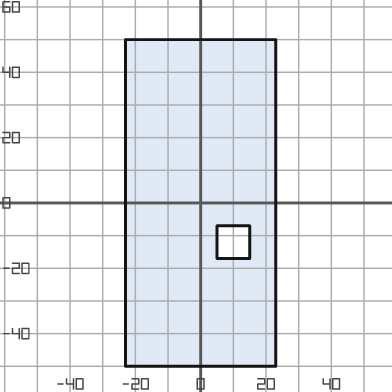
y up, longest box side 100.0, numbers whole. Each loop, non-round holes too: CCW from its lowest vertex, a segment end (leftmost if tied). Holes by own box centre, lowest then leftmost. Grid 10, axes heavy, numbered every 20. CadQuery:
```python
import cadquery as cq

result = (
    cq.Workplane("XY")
    .moveTo(-23.0, -50.0)
    .lineTo(23.0, -50.0)
    .lineTo(23.0, 50.0)
    .lineTo(-23.0, 50.0)
    .close()
    .moveTo(5.0, -17.0)
    .lineTo(15.0, -17.0)
    .lineTo(15.0, -7.0)
    .lineTo(5.0, -7.0)
    .close()
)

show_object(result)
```